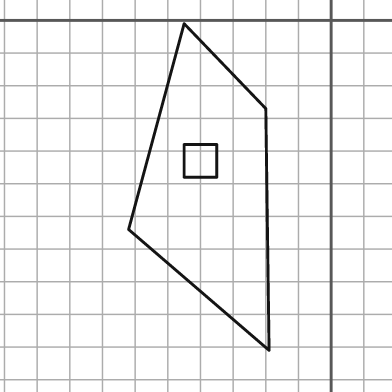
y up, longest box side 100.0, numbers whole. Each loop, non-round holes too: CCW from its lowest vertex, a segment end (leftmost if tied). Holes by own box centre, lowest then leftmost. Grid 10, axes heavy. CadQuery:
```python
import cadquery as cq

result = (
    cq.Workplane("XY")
    .moveTo(-19.0, -101.0)
    .lineTo(-20.0, -27.0)
    .lineTo(-45.0, -1.0)
    .lineTo(-62.0, -64.0)
    .close()
    .moveTo(-45.0, -48.0)
    .lineTo(-35.0, -48.0)
    .lineTo(-35.0, -38.0)
    .lineTo(-45.0, -38.0)
    .close()
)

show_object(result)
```